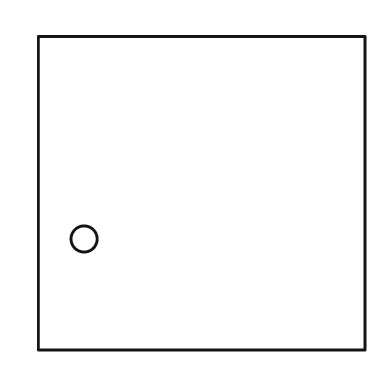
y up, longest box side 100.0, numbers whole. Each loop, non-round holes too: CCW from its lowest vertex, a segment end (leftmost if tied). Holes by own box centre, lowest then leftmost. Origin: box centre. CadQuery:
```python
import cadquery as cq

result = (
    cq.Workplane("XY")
    .moveTo(-50.0, -48.0)
    .lineTo(50.0, -48.0)
    .lineTo(50.0, 48.0)
    .lineTo(-50.0, 48.0)
    .close()
    .moveTo(-36.0, -14.0)
    .circle(4.0)
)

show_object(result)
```